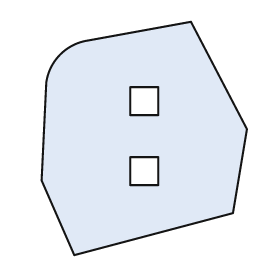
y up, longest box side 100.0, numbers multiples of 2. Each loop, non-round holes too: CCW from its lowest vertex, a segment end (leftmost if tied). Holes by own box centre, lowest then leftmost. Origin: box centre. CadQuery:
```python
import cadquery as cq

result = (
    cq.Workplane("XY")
    .moveTo(-30.0, -50.0)
    .lineTo(38.0, -32.0)
    .lineTo(44.0, 4.0)
    .lineTo(20.0, 50.0)
    .lineTo(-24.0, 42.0)
    .threePointArc((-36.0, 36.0), (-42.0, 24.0))
    .lineTo(-44.0, -18.0)
    .close()
    .moveTo(-6.0, -20.0)
    .lineTo(6.0, -20.0)
    .lineTo(6.0, -8.0)
    .lineTo(-6.0, -8.0)
    .close()
    .moveTo(-6.0, 10.0)
    .lineTo(6.0, 10.0)
    .lineTo(6.0, 22.0)
    .lineTo(-6.0, 22.0)
    .close()
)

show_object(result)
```